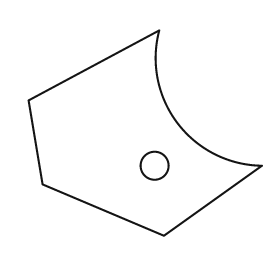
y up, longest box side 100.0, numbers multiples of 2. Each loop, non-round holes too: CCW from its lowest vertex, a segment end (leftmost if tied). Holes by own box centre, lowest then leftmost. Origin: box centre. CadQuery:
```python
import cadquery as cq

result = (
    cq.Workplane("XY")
    .moveTo(8.0, -44.0)
    .lineTo(50.0, -14.0)
    .threePointArc((14.0, 4.0), (6.0, 44.0))
    .lineTo(-50.0, 14.0)
    .lineTo(-44.0, -22.0)
    .close()
    .moveTo(4.0, -14.0)
    .circle(6.0)
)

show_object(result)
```